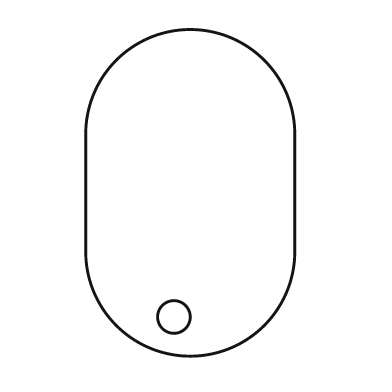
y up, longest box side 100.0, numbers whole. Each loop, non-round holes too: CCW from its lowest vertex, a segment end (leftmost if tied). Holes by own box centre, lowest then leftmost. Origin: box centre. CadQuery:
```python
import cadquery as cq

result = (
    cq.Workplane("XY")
    .moveTo(-32.0, -18.0)
    .threePointArc((0.0, -50.0), (32.0, -18.0))
    .lineTo(32.0, 18.0)
    .threePointArc((0.0, 50.0), (-32.0, 18.0))
    .close()
    .moveTo(-5.0, -38.0)
    .circle(5.0)
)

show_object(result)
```